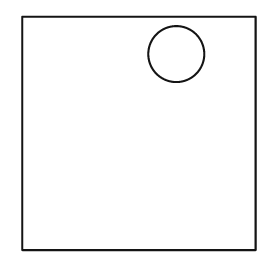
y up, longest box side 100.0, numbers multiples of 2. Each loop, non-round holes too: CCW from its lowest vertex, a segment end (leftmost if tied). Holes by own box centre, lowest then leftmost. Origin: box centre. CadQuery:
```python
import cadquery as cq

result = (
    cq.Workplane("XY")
    .moveTo(-50.0, -50.0)
    .lineTo(50.0, -50.0)
    .lineTo(50.0, 50.0)
    .lineTo(-50.0, 50.0)
    .close()
    .moveTo(16.0, 34.0)
    .circle(12.0)
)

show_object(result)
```